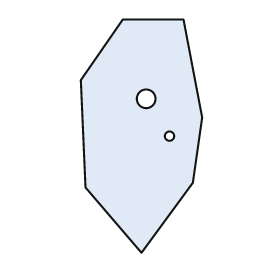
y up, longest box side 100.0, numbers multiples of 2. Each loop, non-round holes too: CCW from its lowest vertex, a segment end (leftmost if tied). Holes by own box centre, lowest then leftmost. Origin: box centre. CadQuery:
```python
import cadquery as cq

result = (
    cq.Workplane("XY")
    .moveTo(0.0, -50.0)
    .lineTo(22.0, -20.0)
    .lineTo(26.0, 8.0)
    .lineTo(18.0, 50.0)
    .lineTo(-8.0, 50.0)
    .lineTo(-26.0, 24.0)
    .lineTo(-24.0, -22.0)
    .close()
    .moveTo(12.0, 0.0)
    .circle(2.0)
    .moveTo(2.0, 16.0)
    .circle(4.0)
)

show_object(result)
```